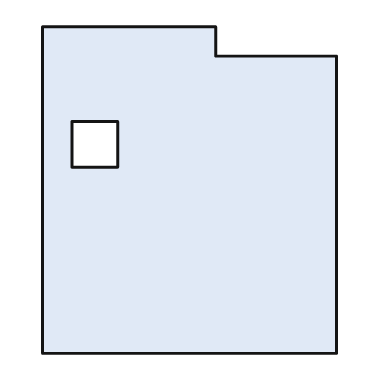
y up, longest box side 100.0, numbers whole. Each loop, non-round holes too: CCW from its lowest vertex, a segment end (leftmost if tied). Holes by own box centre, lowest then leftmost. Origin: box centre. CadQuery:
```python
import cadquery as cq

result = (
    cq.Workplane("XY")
    .moveTo(-45.0, -50.0)
    .lineTo(45.0, -50.0)
    .lineTo(45.0, 41.0)
    .lineTo(8.0, 41.0)
    .lineTo(8.0, 50.0)
    .lineTo(-45.0, 50.0)
    .close()
    .moveTo(-36.0, 7.0)
    .lineTo(-22.0, 7.0)
    .lineTo(-22.0, 21.0)
    .lineTo(-36.0, 21.0)
    .close()
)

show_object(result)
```